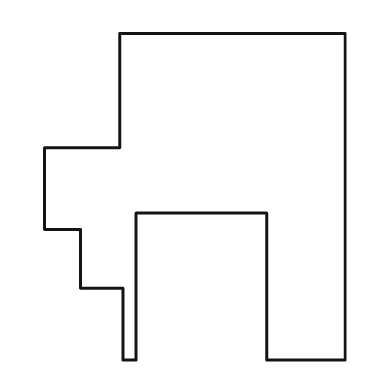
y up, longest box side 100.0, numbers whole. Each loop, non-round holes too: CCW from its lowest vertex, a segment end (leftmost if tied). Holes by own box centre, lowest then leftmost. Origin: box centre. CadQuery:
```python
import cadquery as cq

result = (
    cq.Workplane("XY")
    .moveTo(-22.0, -50.0)
    .lineTo(-18.0, -50.0)
    .lineTo(-18.0, -5.0)
    .lineTo(22.0, -5.0)
    .lineTo(22.0, -50.0)
    .lineTo(46.0, -50.0)
    .lineTo(46.0, 50.0)
    .lineTo(-23.0, 50.0)
    .lineTo(-23.0, 15.0)
    .lineTo(-46.0, 15.0)
    .lineTo(-46.0, -10.0)
    .lineTo(-35.0, -10.0)
    .lineTo(-35.0, -28.0)
    .lineTo(-22.0, -28.0)
    .close()
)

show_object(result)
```